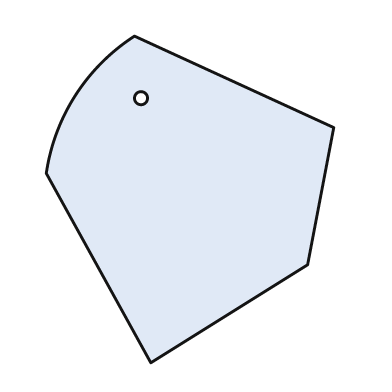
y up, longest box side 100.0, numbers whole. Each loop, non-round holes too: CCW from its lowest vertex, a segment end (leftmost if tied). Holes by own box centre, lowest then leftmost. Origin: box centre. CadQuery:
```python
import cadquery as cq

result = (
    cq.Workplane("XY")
    .moveTo(-12.0, -50.0)
    .lineTo(36.0, -20.0)
    .lineTo(44.0, 22.0)
    .lineTo(-17.0, 50.0)
    .threePointArc((-35.0, 32.0), (-44.0, 8.0))
    .close()
    .moveTo(-15.0, 31.0)
    .circle(2.0)
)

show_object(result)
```